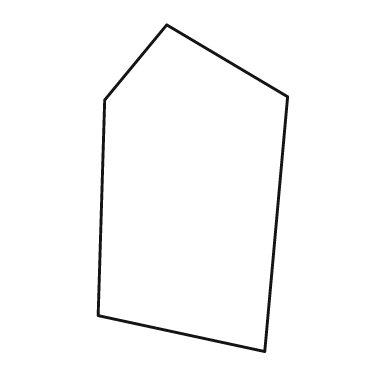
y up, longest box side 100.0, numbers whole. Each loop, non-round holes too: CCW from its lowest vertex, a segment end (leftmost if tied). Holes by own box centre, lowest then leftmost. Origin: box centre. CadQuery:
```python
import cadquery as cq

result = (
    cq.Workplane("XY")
    .moveTo(22.0, -50.0)
    .lineTo(29.0, 28.0)
    .lineTo(-8.0, 50.0)
    .lineTo(-27.0, 27.0)
    .lineTo(-29.0, -39.0)
    .close()
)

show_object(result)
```